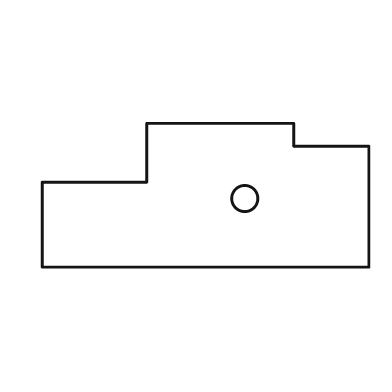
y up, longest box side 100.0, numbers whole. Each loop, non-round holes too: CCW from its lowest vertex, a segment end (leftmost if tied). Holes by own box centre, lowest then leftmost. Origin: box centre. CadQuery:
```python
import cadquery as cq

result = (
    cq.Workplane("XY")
    .moveTo(-50.0, -22.0)
    .lineTo(50.0, -22.0)
    .lineTo(50.0, 15.0)
    .lineTo(27.0, 15.0)
    .lineTo(27.0, 22.0)
    .lineTo(-18.0, 22.0)
    .lineTo(-18.0, 4.0)
    .lineTo(-50.0, 4.0)
    .close()
    .moveTo(12.0, -1.0)
    .circle(4.0)
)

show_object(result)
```